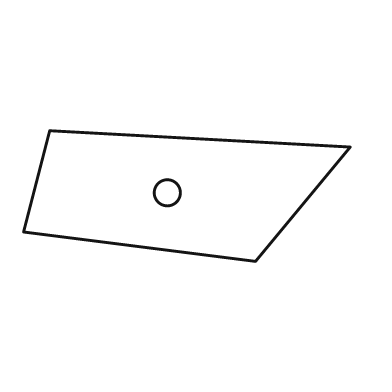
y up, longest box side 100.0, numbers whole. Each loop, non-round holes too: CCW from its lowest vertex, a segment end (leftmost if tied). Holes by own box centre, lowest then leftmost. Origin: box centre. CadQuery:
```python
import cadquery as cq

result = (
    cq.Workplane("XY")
    .moveTo(21.0, -20.0)
    .lineTo(50.0, 15.0)
    .lineTo(-42.0, 20.0)
    .lineTo(-50.0, -11.0)
    .close()
    .moveTo(-6.0, 1.0)
    .circle(4.0)
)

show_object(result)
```